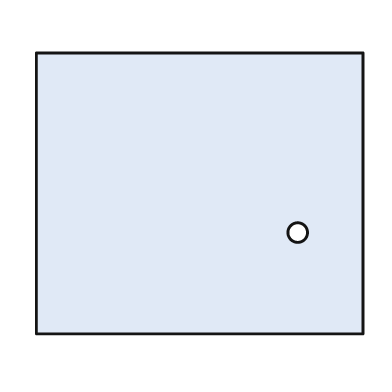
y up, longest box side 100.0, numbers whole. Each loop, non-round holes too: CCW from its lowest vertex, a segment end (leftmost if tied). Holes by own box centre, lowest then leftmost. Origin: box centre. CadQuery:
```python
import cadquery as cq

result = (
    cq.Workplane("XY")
    .moveTo(-50.0, -43.0)
    .lineTo(50.0, -43.0)
    .lineTo(50.0, 43.0)
    .lineTo(-50.0, 43.0)
    .close()
    .moveTo(30.0, -12.0)
    .circle(3.0)
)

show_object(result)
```